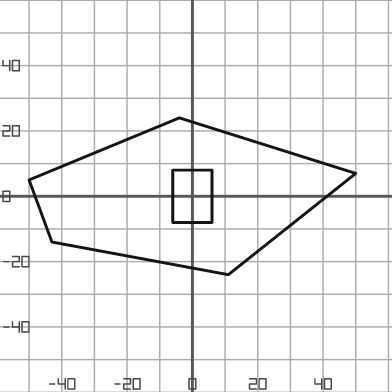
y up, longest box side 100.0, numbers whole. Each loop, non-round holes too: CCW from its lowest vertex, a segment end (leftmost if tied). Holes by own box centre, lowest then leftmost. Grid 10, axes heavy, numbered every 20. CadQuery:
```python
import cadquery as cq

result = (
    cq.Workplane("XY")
    .moveTo(11.0, -24.0)
    .lineTo(50.0, 7.0)
    .lineTo(-4.0, 24.0)
    .lineTo(-50.0, 5.0)
    .lineTo(-43.0, -14.0)
    .close()
    .moveTo(-6.0, -8.0)
    .lineTo(6.0, -8.0)
    .lineTo(6.0, 8.0)
    .lineTo(-6.0, 8.0)
    .close()
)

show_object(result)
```